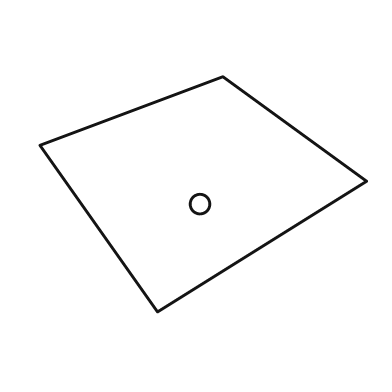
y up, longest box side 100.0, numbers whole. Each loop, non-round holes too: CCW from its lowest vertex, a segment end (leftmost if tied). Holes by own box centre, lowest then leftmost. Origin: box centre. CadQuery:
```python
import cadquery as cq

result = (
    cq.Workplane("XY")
    .moveTo(-14.0, -36.0)
    .lineTo(50.0, 4.0)
    .lineTo(6.0, 36.0)
    .lineTo(-50.0, 15.0)
    .close()
    .moveTo(-1.0, -3.0)
    .circle(3.0)
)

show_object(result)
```